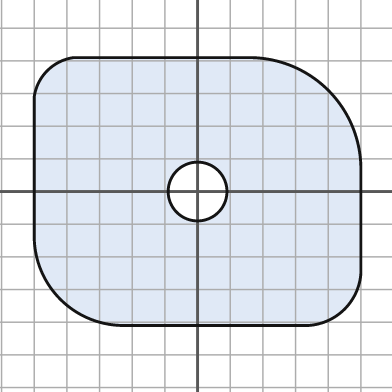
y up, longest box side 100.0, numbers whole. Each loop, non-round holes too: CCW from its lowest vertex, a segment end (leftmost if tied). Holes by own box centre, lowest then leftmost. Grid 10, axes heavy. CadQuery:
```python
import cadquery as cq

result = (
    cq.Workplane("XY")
    .moveTo(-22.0, -41.0)
    .lineTo(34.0, -41.0)
    .threePointArc((45.0, -36.0), (50.0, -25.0))
    .lineTo(50.0, 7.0)
    .threePointArc((40.0, 31.0), (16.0, 41.0))
    .lineTo(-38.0, 41.0)
    .threePointArc((-46.0, 37.0), (-50.0, 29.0))
    .lineTo(-50.0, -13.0)
    .threePointArc((-42.0, -33.0), (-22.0, -41.0))
    .close()
    .moveTo(0.0, 0.0)
    .circle(9.0)
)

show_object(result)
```